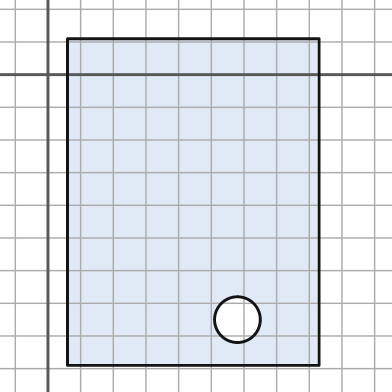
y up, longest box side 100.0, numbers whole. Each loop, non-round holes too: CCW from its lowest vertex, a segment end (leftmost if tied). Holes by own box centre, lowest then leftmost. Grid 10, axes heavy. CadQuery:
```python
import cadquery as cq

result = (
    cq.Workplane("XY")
    .moveTo(6.0, -89.0)
    .lineTo(83.0, -89.0)
    .lineTo(83.0, 11.0)
    .lineTo(6.0, 11.0)
    .close()
    .moveTo(58.0, -75.0)
    .circle(7.0)
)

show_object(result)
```